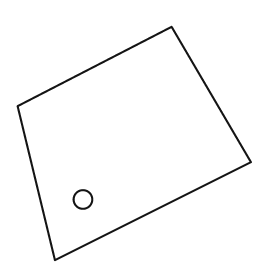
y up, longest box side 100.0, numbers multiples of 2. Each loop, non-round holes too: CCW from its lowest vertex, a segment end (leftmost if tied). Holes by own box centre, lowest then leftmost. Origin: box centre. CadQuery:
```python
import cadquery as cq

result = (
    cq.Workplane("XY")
    .moveTo(-34.0, -50.0)
    .lineTo(50.0, -8.0)
    .lineTo(16.0, 50.0)
    .lineTo(-50.0, 16.0)
    .close()
    .moveTo(-22.0, -24.0)
    .circle(4.0)
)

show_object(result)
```